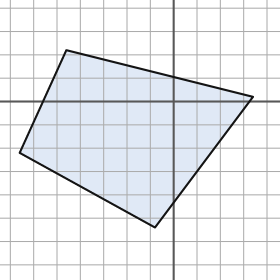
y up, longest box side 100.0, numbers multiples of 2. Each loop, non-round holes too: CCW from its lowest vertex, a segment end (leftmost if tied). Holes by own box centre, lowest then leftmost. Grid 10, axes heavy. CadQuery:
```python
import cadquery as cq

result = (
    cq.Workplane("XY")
    .moveTo(-8.0, -54.0)
    .lineTo(34.0, 2.0)
    .lineTo(-46.0, 22.0)
    .lineTo(-66.0, -22.0)
    .close()
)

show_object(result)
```